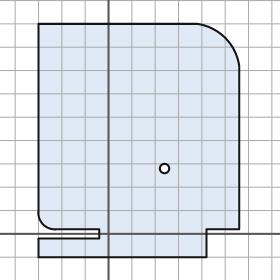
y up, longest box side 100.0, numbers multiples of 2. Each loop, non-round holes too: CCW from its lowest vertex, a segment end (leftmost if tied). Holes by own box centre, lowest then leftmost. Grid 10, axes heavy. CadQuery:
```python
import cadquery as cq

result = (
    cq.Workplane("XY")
    .moveTo(-30.0, -10.0)
    .lineTo(42.0, -10.0)
    .lineTo(42.0, 2.0)
    .lineTo(56.0, 2.0)
    .lineTo(56.0, 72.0)
    .threePointArc((50.0, 84.0), (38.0, 90.0))
    .lineTo(-30.0, 90.0)
    .lineTo(-30.0, 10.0)
    .threePointArc((-28.0, 4.0), (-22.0, 2.0))
    .lineTo(-4.0, 2.0)
    .lineTo(-4.0, -2.0)
    .lineTo(-30.0, -2.0)
    .close()
    .moveTo(24.0, 28.0)
    .circle(2.0)
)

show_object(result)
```